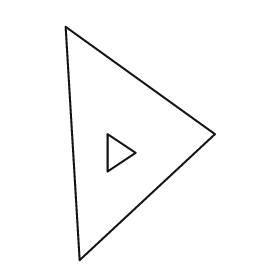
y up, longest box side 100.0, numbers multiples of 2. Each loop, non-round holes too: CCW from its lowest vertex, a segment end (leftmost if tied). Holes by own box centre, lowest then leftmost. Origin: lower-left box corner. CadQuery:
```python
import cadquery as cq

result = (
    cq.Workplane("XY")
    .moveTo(6.0, 0.0)
    .lineTo(64.0, 54.0)
    .lineTo(0.0, 100.0)
    .close()
    .moveTo(18.0, 38.0)
    .lineTo(30.0, 46.0)
    .lineTo(18.0, 54.0)
    .close()
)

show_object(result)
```